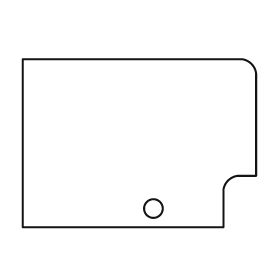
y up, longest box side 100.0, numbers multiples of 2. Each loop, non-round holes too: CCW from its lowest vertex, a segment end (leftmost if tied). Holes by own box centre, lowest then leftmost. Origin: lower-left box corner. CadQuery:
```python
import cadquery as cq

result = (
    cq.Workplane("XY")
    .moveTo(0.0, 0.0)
    .lineTo(86.0, 0.0)
    .lineTo(86.0, 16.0)
    .threePointArc((88.0, 20.0), (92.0, 22.0))
    .lineTo(100.0, 22.0)
    .lineTo(100.0, 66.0)
    .threePointArc((98.0, 70.0), (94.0, 72.0))
    .lineTo(0.0, 72.0)
    .close()
    .moveTo(56.0, 8.0)
    .circle(4.0)
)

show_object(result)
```